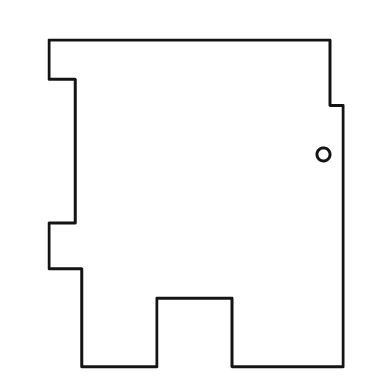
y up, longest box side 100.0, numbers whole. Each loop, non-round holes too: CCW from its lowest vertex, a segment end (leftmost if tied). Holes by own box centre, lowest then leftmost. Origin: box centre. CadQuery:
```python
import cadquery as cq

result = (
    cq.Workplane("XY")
    .moveTo(-35.0, -50.0)
    .lineTo(-12.0, -50.0)
    .lineTo(-12.0, -29.0)
    .lineTo(11.0, -29.0)
    .lineTo(11.0, -50.0)
    .lineTo(45.0, -50.0)
    .lineTo(45.0, 30.0)
    .lineTo(41.0, 30.0)
    .lineTo(41.0, 50.0)
    .lineTo(-45.0, 50.0)
    .lineTo(-45.0, 38.0)
    .lineTo(-37.0, 38.0)
    .lineTo(-37.0, -6.0)
    .lineTo(-45.0, -6.0)
    .lineTo(-45.0, -20.0)
    .lineTo(-35.0, -20.0)
    .close()
    .moveTo(39.0, 15.0)
    .circle(2.0)
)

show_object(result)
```